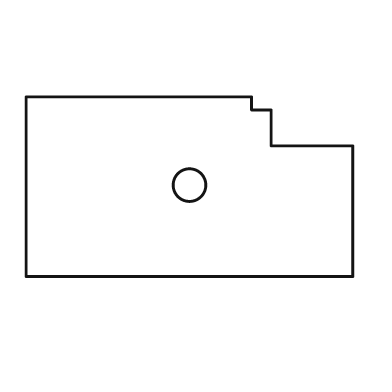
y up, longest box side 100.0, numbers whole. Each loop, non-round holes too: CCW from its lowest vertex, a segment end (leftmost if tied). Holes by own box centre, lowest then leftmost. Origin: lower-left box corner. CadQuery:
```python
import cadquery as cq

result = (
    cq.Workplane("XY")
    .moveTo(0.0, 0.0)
    .lineTo(100.0, 0.0)
    .lineTo(100.0, 40.0)
    .lineTo(75.0, 40.0)
    .lineTo(75.0, 51.0)
    .lineTo(69.0, 51.0)
    .lineTo(69.0, 55.0)
    .lineTo(0.0, 55.0)
    .close()
    .moveTo(50.0, 28.0)
    .circle(5.0)
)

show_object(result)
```